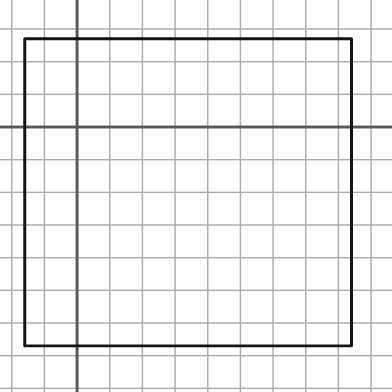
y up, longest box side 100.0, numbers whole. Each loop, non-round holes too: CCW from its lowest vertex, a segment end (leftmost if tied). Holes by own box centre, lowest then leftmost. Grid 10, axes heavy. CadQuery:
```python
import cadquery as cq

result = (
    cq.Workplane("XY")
    .moveTo(-16.0, -67.0)
    .lineTo(84.0, -67.0)
    .lineTo(84.0, 27.0)
    .lineTo(-16.0, 27.0)
    .close()
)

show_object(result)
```